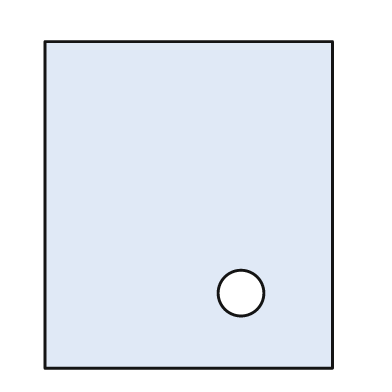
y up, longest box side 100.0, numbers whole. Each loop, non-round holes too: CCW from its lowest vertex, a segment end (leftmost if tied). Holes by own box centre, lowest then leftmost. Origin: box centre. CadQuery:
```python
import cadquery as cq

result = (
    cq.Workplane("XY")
    .moveTo(-44.0, -50.0)
    .lineTo(44.0, -50.0)
    .lineTo(44.0, 50.0)
    .lineTo(-44.0, 50.0)
    .close()
    .moveTo(16.0, -27.0)
    .circle(7.0)
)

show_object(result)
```